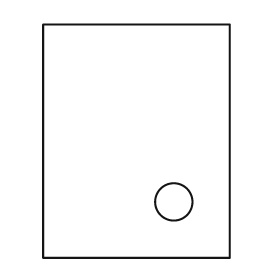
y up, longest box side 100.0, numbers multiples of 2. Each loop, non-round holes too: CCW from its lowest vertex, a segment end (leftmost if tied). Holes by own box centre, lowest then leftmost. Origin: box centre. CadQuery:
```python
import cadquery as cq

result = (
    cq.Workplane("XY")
    .moveTo(-40.0, -50.0)
    .lineTo(40.0, -50.0)
    .lineTo(40.0, 50.0)
    .lineTo(-40.0, 50.0)
    .close()
    .moveTo(16.0, -26.0)
    .circle(8.0)
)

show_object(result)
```